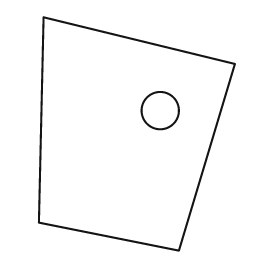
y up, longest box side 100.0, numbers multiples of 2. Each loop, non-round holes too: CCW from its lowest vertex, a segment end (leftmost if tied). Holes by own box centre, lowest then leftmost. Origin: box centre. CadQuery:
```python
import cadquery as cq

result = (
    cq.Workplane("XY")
    .moveTo(18.0, -50.0)
    .lineTo(42.0, 30.0)
    .lineTo(-40.0, 50.0)
    .lineTo(-42.0, -38.0)
    .close()
    .moveTo(10.0, 10.0)
    .circle(8.0)
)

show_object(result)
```